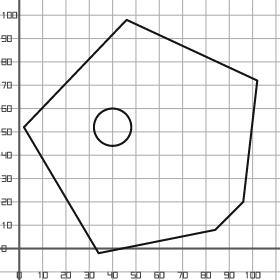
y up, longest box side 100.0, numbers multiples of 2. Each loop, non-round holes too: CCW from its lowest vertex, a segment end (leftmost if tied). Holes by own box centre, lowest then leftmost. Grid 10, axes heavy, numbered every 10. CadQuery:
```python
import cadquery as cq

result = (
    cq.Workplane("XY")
    .moveTo(34.0, -2.0)
    .lineTo(84.0, 8.0)
    .lineTo(96.0, 20.0)
    .lineTo(102.0, 72.0)
    .lineTo(46.0, 98.0)
    .lineTo(2.0, 52.0)
    .close()
    .moveTo(40.0, 52.0)
    .circle(8.0)
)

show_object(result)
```